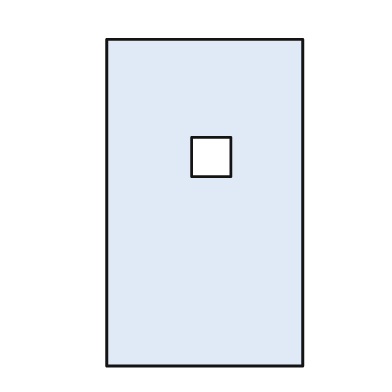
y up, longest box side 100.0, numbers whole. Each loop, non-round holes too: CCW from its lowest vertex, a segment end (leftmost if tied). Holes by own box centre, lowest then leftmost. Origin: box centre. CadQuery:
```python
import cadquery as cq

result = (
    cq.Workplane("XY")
    .moveTo(-30.0, -50.0)
    .lineTo(30.0, -50.0)
    .lineTo(30.0, 50.0)
    .lineTo(-30.0, 50.0)
    .close()
    .moveTo(-4.0, 8.0)
    .lineTo(8.0, 8.0)
    .lineTo(8.0, 20.0)
    .lineTo(-4.0, 20.0)
    .close()
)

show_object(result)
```